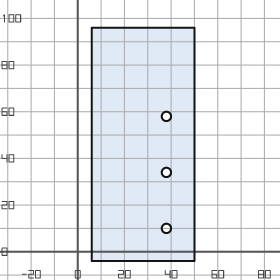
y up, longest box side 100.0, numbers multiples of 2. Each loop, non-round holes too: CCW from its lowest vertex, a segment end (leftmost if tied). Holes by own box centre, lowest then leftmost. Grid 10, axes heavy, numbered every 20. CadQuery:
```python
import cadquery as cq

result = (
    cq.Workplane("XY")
    .moveTo(6.0, -4.0)
    .lineTo(50.0, -4.0)
    .lineTo(50.0, 96.0)
    .lineTo(6.0, 96.0)
    .close()
    .moveTo(38.0, 10.0)
    .circle(2.0)
    .moveTo(38.0, 34.0)
    .circle(2.0)
    .moveTo(38.0, 58.0)
    .circle(2.0)
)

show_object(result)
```